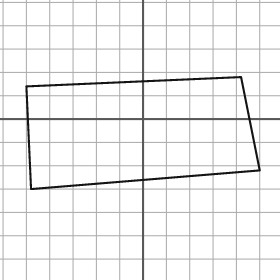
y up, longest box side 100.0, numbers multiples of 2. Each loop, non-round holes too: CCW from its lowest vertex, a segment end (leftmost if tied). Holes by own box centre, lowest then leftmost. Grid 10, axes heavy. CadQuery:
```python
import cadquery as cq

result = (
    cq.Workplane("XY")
    .moveTo(-48.0, -30.0)
    .lineTo(50.0, -22.0)
    .lineTo(42.0, 18.0)
    .lineTo(-50.0, 14.0)
    .close()
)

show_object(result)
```